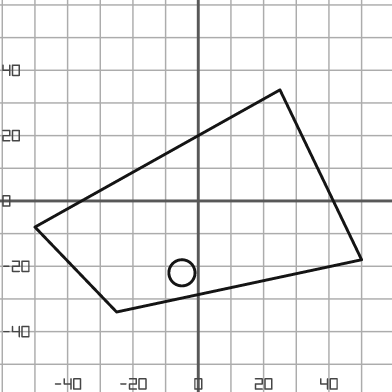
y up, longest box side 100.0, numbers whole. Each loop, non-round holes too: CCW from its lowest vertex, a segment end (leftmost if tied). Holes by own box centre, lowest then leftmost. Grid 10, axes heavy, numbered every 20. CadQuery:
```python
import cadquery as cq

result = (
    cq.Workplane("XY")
    .moveTo(-25.0, -34.0)
    .lineTo(50.0, -18.0)
    .lineTo(25.0, 34.0)
    .lineTo(-50.0, -8.0)
    .close()
    .moveTo(-5.0, -22.0)
    .circle(4.0)
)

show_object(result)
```